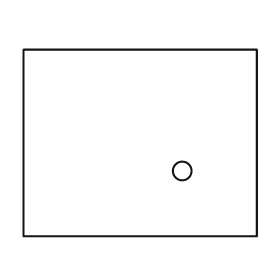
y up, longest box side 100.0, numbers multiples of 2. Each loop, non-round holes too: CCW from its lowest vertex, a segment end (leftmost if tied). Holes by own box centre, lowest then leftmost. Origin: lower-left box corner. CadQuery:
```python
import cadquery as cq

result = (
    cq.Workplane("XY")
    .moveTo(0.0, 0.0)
    .lineTo(100.0, 0.0)
    .lineTo(100.0, 80.0)
    .lineTo(0.0, 80.0)
    .close()
    .moveTo(68.0, 28.0)
    .circle(4.0)
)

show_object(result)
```